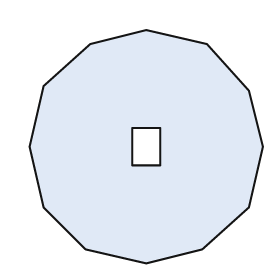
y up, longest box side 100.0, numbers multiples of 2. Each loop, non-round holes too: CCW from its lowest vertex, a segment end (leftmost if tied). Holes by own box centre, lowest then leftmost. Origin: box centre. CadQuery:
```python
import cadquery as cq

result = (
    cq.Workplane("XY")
    .moveTo(0.0, -50.0)
    .lineTo(24.0, -44.0)
    .lineTo(44.0, -26.0)
    .lineTo(50.0, 0.0)
    .lineTo(44.0, 24.0)
    .lineTo(26.0, 44.0)
    .lineTo(0.0, 50.0)
    .lineTo(-24.0, 44.0)
    .lineTo(-44.0, 26.0)
    .lineTo(-50.0, 0.0)
    .lineTo(-44.0, -26.0)
    .lineTo(-26.0, -44.0)
    .close()
    .moveTo(-6.0, -8.0)
    .lineTo(6.0, -8.0)
    .lineTo(6.0, 8.0)
    .lineTo(-6.0, 8.0)
    .close()
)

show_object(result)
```